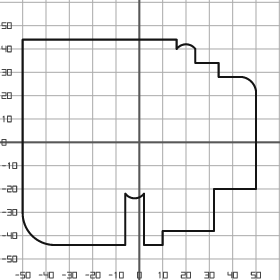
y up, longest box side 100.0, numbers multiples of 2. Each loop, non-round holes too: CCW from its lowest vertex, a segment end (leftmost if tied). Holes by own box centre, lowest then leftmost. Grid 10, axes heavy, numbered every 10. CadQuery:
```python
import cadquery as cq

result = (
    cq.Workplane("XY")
    .moveTo(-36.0, -44.0)
    .lineTo(-6.0, -44.0)
    .lineTo(-6.0, -22.0)
    .threePointArc((-2.0, -24.0), (2.0, -22.0))
    .lineTo(2.0, -44.0)
    .lineTo(10.0, -44.0)
    .lineTo(10.0, -38.0)
    .lineTo(32.0, -38.0)
    .lineTo(32.0, -20.0)
    .lineTo(50.0, -20.0)
    .lineTo(50.0, 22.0)
    .threePointArc((48.0, 26.0), (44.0, 28.0))
    .lineTo(34.0, 28.0)
    .lineTo(34.0, 34.0)
    .lineTo(24.0, 34.0)
    .lineTo(24.0, 40.0)
    .threePointArc((20.0, 42.0), (16.0, 40.0))
    .lineTo(16.0, 44.0)
    .lineTo(-50.0, 44.0)
    .lineTo(-50.0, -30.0)
    .threePointArc((-46.0, -40.0), (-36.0, -44.0))
    .close()
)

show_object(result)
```